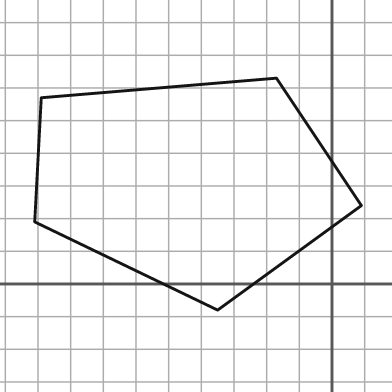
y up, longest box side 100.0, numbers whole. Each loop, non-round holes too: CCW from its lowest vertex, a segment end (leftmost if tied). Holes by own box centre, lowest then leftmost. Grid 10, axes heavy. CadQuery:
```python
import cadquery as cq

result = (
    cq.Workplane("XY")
    .moveTo(-35.0, -8.0)
    .lineTo(9.0, 24.0)
    .lineTo(-17.0, 63.0)
    .lineTo(-89.0, 57.0)
    .lineTo(-91.0, 19.0)
    .close()
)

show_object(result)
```